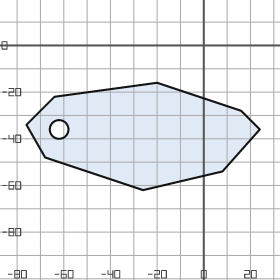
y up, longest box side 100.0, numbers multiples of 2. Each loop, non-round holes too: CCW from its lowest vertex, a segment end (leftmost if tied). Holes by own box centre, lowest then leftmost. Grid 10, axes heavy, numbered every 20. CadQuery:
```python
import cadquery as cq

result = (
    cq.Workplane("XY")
    .moveTo(-26.0, -62.0)
    .lineTo(8.0, -54.0)
    .lineTo(24.0, -36.0)
    .lineTo(16.0, -28.0)
    .lineTo(-20.0, -16.0)
    .lineTo(-64.0, -22.0)
    .lineTo(-76.0, -34.0)
    .lineTo(-68.0, -48.0)
    .close()
    .moveTo(-62.0, -36.0)
    .circle(4.0)
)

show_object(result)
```